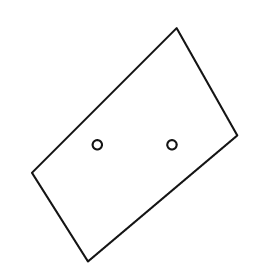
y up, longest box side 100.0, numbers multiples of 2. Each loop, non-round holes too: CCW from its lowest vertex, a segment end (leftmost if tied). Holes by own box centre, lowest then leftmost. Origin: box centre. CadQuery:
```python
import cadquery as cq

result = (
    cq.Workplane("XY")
    .moveTo(-20.0, -50.0)
    .lineTo(44.0, 4.0)
    .lineTo(18.0, 50.0)
    .lineTo(-44.0, -12.0)
    .close()
    .moveTo(-16.0, 0.0)
    .circle(2.0)
    .moveTo(16.0, 0.0)
    .circle(2.0)
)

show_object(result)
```